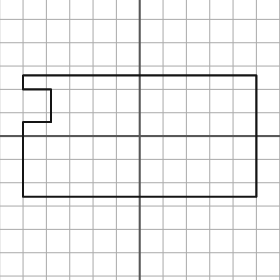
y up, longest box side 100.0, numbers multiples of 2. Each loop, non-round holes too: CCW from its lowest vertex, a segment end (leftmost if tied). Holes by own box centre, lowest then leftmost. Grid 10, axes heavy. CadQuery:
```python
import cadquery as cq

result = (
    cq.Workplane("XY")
    .moveTo(-50.0, -26.0)
    .lineTo(50.0, -26.0)
    .lineTo(50.0, 26.0)
    .lineTo(-50.0, 26.0)
    .lineTo(-50.0, 20.0)
    .lineTo(-38.0, 20.0)
    .lineTo(-38.0, 6.0)
    .lineTo(-50.0, 6.0)
    .close()
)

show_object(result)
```